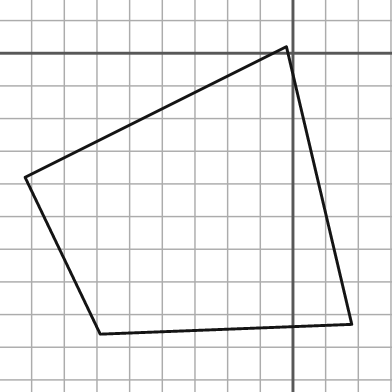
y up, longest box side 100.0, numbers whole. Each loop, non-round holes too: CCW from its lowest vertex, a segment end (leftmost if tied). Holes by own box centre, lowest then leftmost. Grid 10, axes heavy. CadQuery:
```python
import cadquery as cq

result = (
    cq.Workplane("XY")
    .moveTo(-59.0, -86.0)
    .lineTo(18.0, -83.0)
    .lineTo(-2.0, 2.0)
    .lineTo(-82.0, -38.0)
    .close()
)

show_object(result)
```